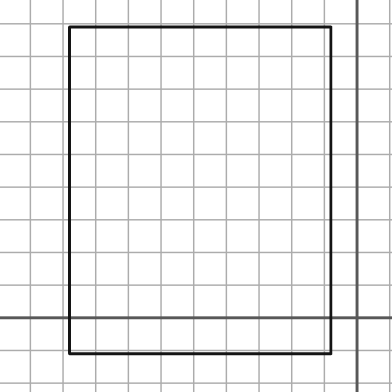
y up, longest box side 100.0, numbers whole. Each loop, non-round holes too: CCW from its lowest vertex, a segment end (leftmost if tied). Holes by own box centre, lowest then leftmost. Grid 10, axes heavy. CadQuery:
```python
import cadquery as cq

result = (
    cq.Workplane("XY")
    .moveTo(-88.0, -11.0)
    .lineTo(-8.0, -11.0)
    .lineTo(-8.0, 89.0)
    .lineTo(-88.0, 89.0)
    .close()
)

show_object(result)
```